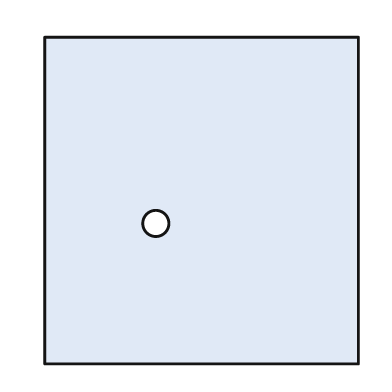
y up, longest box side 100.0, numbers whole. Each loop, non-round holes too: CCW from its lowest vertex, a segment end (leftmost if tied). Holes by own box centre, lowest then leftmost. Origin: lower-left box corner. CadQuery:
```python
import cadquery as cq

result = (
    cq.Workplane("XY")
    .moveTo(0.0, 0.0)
    .lineTo(96.0, 0.0)
    .lineTo(96.0, 100.0)
    .lineTo(0.0, 100.0)
    .close()
    .moveTo(34.0, 43.0)
    .circle(4.0)
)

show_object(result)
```